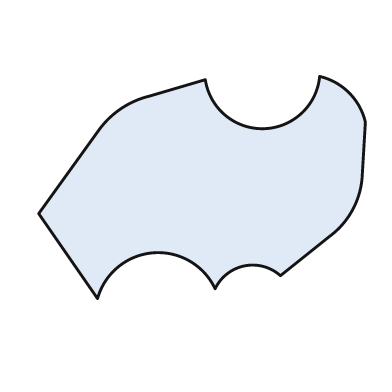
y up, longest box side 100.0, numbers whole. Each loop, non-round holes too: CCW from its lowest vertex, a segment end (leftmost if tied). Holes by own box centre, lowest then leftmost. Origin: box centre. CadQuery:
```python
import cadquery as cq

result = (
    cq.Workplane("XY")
    .moveTo(-32.0, -34.0)
    .threePointArc((-15.0, -20.0), (4.0, -31.0))
    .threePointArc((13.0, -24.0), (24.0, -27.0))
    .lineTo(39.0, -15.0)
    .threePointArc((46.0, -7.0), (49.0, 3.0))
    .lineTo(50.0, 20.0)
    .threePointArc((45.0, 29.0), (36.0, 34.0))
    .threePointArc((19.0, 18.0), (1.0, 33.0))
    .lineTo(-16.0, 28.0)
    .threePointArc((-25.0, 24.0), (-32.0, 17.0))
    .lineTo(-50.0, -8.0)
    .close()
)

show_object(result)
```